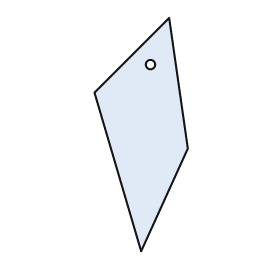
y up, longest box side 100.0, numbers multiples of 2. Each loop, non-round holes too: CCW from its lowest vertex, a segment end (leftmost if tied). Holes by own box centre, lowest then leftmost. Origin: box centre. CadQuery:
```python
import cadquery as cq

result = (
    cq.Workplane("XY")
    .moveTo(0.0, -50.0)
    .lineTo(20.0, -6.0)
    .lineTo(12.0, 50.0)
    .lineTo(-20.0, 18.0)
    .close()
    .moveTo(4.0, 30.0)
    .circle(2.0)
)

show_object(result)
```